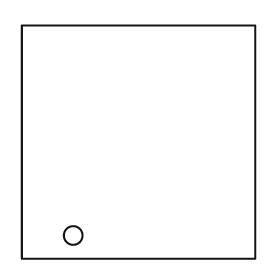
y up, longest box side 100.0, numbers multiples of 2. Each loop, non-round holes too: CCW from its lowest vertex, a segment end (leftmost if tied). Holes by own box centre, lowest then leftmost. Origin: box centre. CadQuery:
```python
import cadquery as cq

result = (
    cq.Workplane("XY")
    .moveTo(-50.0, -50.0)
    .lineTo(50.0, -50.0)
    .lineTo(50.0, 50.0)
    .lineTo(-50.0, 50.0)
    .close()
    .moveTo(-28.0, -40.0)
    .circle(4.0)
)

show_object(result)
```